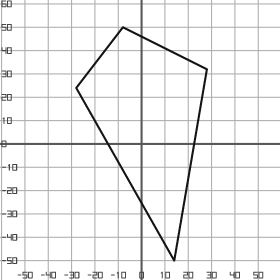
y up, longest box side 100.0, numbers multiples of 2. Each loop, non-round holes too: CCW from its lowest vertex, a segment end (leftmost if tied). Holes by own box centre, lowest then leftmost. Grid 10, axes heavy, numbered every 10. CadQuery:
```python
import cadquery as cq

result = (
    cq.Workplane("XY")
    .moveTo(14.0, -50.0)
    .lineTo(28.0, 32.0)
    .lineTo(-8.0, 50.0)
    .lineTo(-28.0, 24.0)
    .close()
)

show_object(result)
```